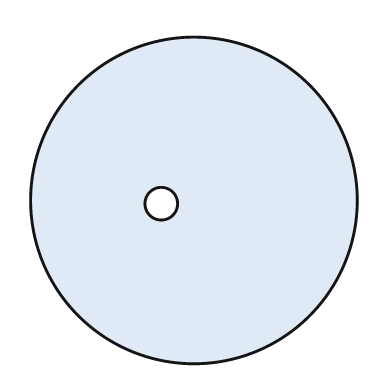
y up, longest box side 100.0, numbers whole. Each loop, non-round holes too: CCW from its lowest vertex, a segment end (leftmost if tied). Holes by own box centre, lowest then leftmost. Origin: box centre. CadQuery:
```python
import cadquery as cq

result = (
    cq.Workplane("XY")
    .moveTo(0.0, 0.0)
    .circle(50.0)
    .moveTo(-10.0, -1.0)
    .circle(5.0)
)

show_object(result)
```